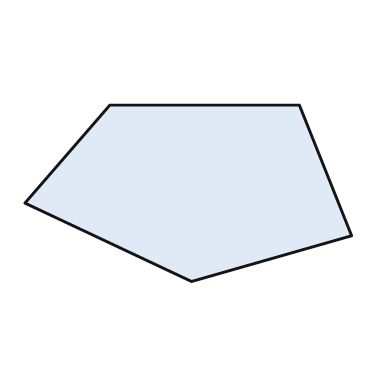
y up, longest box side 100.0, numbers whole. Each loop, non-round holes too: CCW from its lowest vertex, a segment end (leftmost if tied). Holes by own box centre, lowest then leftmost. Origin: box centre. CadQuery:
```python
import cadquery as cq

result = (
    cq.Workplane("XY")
    .moveTo(1.0, -27.0)
    .lineTo(50.0, -13.0)
    .lineTo(34.0, 27.0)
    .lineTo(-24.0, 27.0)
    .lineTo(-50.0, -3.0)
    .close()
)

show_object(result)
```